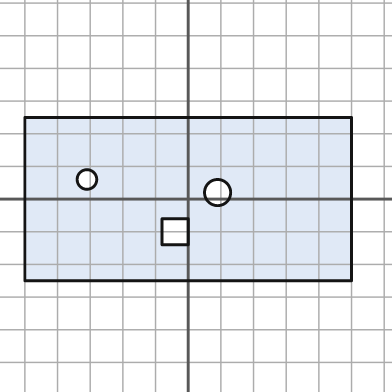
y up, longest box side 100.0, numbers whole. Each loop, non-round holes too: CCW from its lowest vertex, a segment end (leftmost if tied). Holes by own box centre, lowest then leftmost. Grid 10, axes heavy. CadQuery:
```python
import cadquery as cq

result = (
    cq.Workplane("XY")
    .moveTo(-50.0, -25.0)
    .lineTo(50.0, -25.0)
    .lineTo(50.0, 25.0)
    .lineTo(-50.0, 25.0)
    .close()
    .moveTo(-8.0, -14.0)
    .lineTo(0.0, -14.0)
    .lineTo(0.0, -6.0)
    .lineTo(-8.0, -6.0)
    .close()
    .moveTo(9.0, 2.0)
    .circle(4.0)
    .moveTo(-31.0, 6.0)
    .circle(3.0)
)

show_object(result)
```